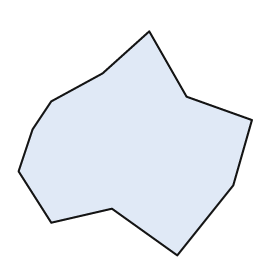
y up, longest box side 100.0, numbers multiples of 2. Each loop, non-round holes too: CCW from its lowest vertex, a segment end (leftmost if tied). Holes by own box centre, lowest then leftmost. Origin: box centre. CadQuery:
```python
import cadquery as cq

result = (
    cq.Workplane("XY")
    .moveTo(18.0, -48.0)
    .lineTo(42.0, -18.0)
    .lineTo(50.0, 10.0)
    .lineTo(22.0, 20.0)
    .lineTo(6.0, 48.0)
    .lineTo(-14.0, 30.0)
    .lineTo(-36.0, 18.0)
    .lineTo(-44.0, 6.0)
    .lineTo(-50.0, -12.0)
    .lineTo(-36.0, -34.0)
    .lineTo(-10.0, -28.0)
    .close()
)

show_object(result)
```